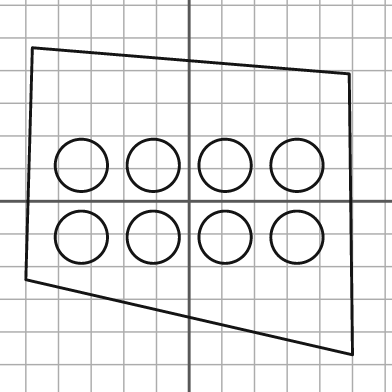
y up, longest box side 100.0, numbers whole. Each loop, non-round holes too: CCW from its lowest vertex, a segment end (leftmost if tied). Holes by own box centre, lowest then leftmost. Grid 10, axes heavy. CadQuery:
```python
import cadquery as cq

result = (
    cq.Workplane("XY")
    .moveTo(50.0, -47.0)
    .lineTo(49.0, 39.0)
    .lineTo(-48.0, 47.0)
    .lineTo(-50.0, -24.0)
    .close()
    .moveTo(-33.0, -11.0)
    .circle(8.0)
    .moveTo(-11.0, -11.0)
    .circle(8.0)
    .moveTo(11.0, -11.0)
    .circle(8.0)
    .moveTo(33.0, -11.0)
    .circle(8.0)
    .moveTo(-33.0, 11.0)
    .circle(8.0)
    .moveTo(-11.0, 11.0)
    .circle(8.0)
    .moveTo(11.0, 11.0)
    .circle(8.0)
    .moveTo(33.0, 11.0)
    .circle(8.0)
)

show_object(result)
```